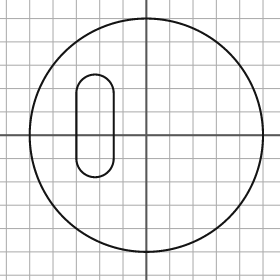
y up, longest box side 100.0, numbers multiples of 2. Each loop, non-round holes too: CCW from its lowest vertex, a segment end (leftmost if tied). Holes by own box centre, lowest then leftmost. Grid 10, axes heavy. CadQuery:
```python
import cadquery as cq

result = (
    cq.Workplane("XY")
    .moveTo(0.0, 0.0)
    .circle(50.0)
    .moveTo(-30.0, -10.0)
    .threePointArc((-22.0, -18.0), (-14.0, -10.0))
    .lineTo(-14.0, 18.0)
    .threePointArc((-22.0, 26.0), (-30.0, 18.0))
    .close()
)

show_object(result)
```